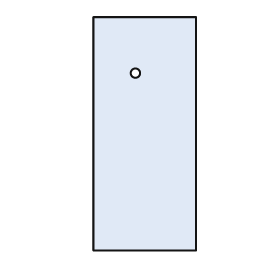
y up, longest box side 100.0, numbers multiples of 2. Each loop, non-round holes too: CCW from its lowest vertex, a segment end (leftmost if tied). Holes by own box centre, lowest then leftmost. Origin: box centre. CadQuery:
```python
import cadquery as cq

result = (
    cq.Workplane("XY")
    .moveTo(-22.0, -50.0)
    .lineTo(22.0, -50.0)
    .lineTo(22.0, 50.0)
    .lineTo(-22.0, 50.0)
    .close()
    .moveTo(-4.0, 26.0)
    .circle(2.0)
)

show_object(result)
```